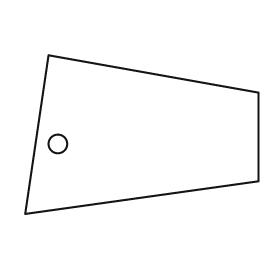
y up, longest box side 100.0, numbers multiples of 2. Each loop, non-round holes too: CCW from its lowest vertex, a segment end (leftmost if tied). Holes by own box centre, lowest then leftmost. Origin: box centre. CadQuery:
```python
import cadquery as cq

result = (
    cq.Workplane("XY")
    .moveTo(-50.0, -34.0)
    .lineTo(50.0, -20.0)
    .lineTo(50.0, 18.0)
    .lineTo(-40.0, 34.0)
    .close()
    .moveTo(-36.0, -4.0)
    .circle(4.0)
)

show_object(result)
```